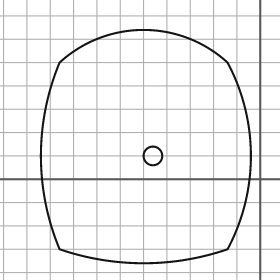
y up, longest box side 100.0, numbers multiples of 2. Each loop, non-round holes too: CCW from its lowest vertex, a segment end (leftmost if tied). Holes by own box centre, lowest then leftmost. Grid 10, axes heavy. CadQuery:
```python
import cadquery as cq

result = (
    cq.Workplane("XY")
    .moveTo(-86.0, -30.0)
    .threePointArc((-50.0, -36.0), (-14.0, -30.0))
    .threePointArc((-4.0, 10.0), (-14.0, 50.0))
    .threePointArc((-50.0, 64.0), (-86.0, 50.0))
    .threePointArc((-94.0, 10.0), (-86.0, -30.0))
    .close()
    .moveTo(-46.0, 10.0)
    .circle(4.0)
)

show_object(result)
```